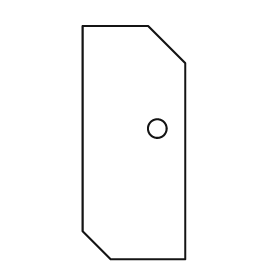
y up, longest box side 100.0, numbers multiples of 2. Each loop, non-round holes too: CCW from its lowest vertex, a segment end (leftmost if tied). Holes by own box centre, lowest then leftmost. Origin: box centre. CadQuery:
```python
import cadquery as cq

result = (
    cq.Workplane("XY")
    .moveTo(-10.0, -50.0)
    .lineTo(22.0, -50.0)
    .lineTo(22.0, 34.0)
    .lineTo(6.0, 50.0)
    .lineTo(-22.0, 50.0)
    .lineTo(-22.0, -38.0)
    .close()
    .moveTo(10.0, 6.0)
    .circle(4.0)
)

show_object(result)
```